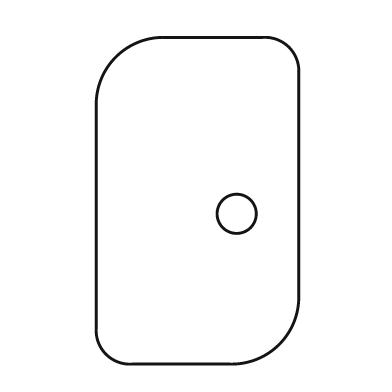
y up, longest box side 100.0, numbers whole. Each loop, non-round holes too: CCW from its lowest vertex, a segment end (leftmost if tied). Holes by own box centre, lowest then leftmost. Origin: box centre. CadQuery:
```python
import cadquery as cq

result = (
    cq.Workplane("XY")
    .moveTo(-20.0, -50.0)
    .lineTo(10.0, -50.0)
    .threePointArc((25.0, -44.0), (31.0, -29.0))
    .lineTo(31.0, 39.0)
    .threePointArc((28.0, 47.0), (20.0, 50.0))
    .lineTo(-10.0, 50.0)
    .threePointArc((-25.0, 44.0), (-31.0, 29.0))
    .lineTo(-31.0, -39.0)
    .threePointArc((-28.0, -47.0), (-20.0, -50.0))
    .close()
    .moveTo(12.0, -4.0)
    .circle(6.0)
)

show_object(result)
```